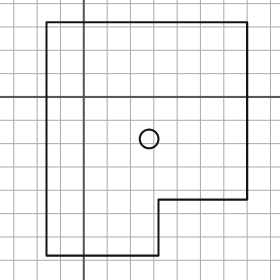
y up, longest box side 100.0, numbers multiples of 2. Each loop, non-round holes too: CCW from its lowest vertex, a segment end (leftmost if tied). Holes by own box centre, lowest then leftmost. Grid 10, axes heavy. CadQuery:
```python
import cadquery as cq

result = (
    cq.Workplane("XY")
    .moveTo(-16.0, -68.0)
    .lineTo(32.0, -68.0)
    .lineTo(32.0, -44.0)
    .lineTo(70.0, -44.0)
    .lineTo(70.0, 32.0)
    .lineTo(-16.0, 32.0)
    .close()
    .moveTo(28.0, -18.0)
    .circle(4.0)
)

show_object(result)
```